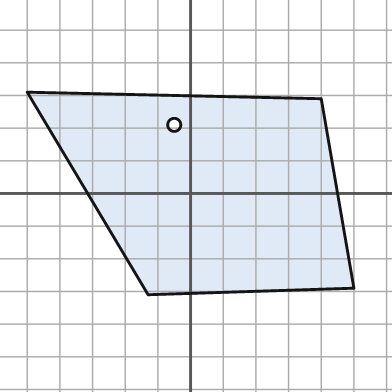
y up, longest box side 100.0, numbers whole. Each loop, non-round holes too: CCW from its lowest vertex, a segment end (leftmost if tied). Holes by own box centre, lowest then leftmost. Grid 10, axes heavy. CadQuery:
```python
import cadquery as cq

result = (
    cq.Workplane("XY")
    .moveTo(-13.0, -31.0)
    .lineTo(50.0, -29.0)
    .lineTo(40.0, 29.0)
    .lineTo(-50.0, 31.0)
    .close()
    .moveTo(-5.0, 21.0)
    .circle(2.0)
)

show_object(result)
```